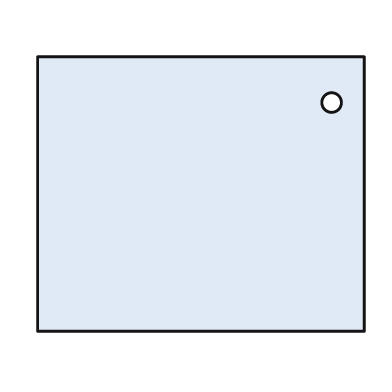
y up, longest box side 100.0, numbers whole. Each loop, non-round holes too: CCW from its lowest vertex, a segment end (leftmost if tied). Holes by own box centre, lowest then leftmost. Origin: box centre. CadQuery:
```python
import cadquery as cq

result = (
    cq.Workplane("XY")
    .moveTo(-50.0, -42.0)
    .lineTo(50.0, -42.0)
    .lineTo(50.0, 42.0)
    .lineTo(-50.0, 42.0)
    .close()
    .moveTo(40.0, 28.0)
    .circle(3.0)
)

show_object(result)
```